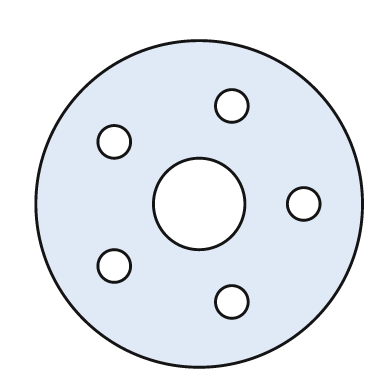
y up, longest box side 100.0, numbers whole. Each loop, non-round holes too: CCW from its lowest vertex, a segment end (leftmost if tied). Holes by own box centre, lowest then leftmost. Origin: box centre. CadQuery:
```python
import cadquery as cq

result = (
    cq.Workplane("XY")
    .moveTo(0.0, 0.0)
    .circle(50.0)
    .moveTo(10.0, -30.0)
    .circle(5.0)
    .moveTo(-26.0, -19.0)
    .circle(5.0)
    .moveTo(0.0, 0.0)
    .circle(14.0)
    .moveTo(32.0, 0.0)
    .circle(5.0)
    .moveTo(-26.0, 19.0)
    .circle(5.0)
    .moveTo(10.0, 30.0)
    .circle(5.0)
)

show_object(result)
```